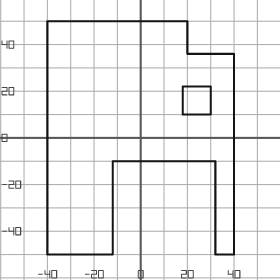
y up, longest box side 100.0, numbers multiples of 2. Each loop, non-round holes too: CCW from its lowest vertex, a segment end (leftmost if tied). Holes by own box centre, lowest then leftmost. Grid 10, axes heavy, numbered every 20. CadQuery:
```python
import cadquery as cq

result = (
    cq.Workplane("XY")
    .moveTo(-40.0, -50.0)
    .lineTo(-12.0, -50.0)
    .lineTo(-12.0, -10.0)
    .lineTo(32.0, -10.0)
    .lineTo(32.0, -50.0)
    .lineTo(40.0, -50.0)
    .lineTo(40.0, 36.0)
    .lineTo(20.0, 36.0)
    .lineTo(20.0, 50.0)
    .lineTo(-40.0, 50.0)
    .close()
    .moveTo(18.0, 10.0)
    .lineTo(30.0, 10.0)
    .lineTo(30.0, 22.0)
    .lineTo(18.0, 22.0)
    .close()
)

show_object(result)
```